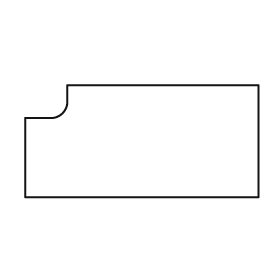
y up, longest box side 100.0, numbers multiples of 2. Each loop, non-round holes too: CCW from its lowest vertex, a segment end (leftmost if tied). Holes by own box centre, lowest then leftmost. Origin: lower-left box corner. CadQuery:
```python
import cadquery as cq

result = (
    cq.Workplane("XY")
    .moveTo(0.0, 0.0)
    .lineTo(100.0, 0.0)
    .lineTo(100.0, 48.0)
    .lineTo(18.0, 48.0)
    .lineTo(18.0, 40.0)
    .threePointArc((16.0, 36.0), (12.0, 34.0))
    .lineTo(0.0, 34.0)
    .close()
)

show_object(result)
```